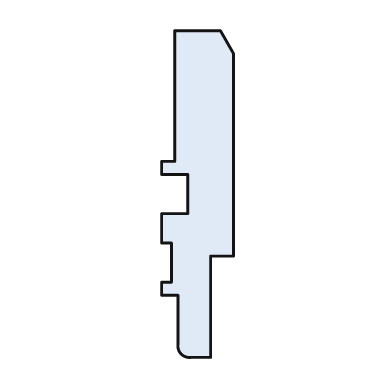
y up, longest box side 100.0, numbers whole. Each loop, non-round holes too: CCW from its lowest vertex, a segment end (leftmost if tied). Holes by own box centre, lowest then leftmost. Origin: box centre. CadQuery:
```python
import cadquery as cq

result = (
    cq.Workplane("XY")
    .moveTo(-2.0, -50.0)
    .lineTo(4.0, -50.0)
    .lineTo(4.0, -19.0)
    .lineTo(11.0, -19.0)
    .lineTo(11.0, 43.0)
    .lineTo(7.0, 50.0)
    .lineTo(-7.0, 50.0)
    .lineTo(-7.0, 10.0)
    .lineTo(-11.0, 10.0)
    .lineTo(-11.0, 6.0)
    .lineTo(-3.0, 6.0)
    .lineTo(-3.0, -6.0)
    .lineTo(-11.0, -6.0)
    .lineTo(-11.0, -15.0)
    .lineTo(-8.0, -15.0)
    .lineTo(-8.0, -27.0)
    .lineTo(-11.0, -27.0)
    .lineTo(-11.0, -31.0)
    .lineTo(-6.0, -31.0)
    .lineTo(-6.0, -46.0)
    .threePointArc((-5.0, -49.0), (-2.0, -50.0))
    .close()
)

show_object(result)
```